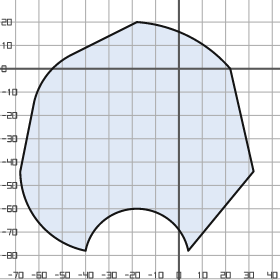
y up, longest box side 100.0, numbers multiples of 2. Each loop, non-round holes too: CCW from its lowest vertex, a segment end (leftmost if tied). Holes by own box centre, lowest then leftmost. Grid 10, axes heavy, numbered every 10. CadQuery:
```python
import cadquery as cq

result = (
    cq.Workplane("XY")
    .moveTo(-40.0, -78.0)
    .threePointArc((-18.0, -60.0), (4.0, -78.0))
    .lineTo(32.0, -44.0)
    .lineTo(22.0, 0.0)
    .threePointArc((4.0, 14.0), (-18.0, 20.0))
    .lineTo(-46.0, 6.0)
    .threePointArc((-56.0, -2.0), (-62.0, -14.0))
    .lineTo(-68.0, -44.0)
    .threePointArc((-60.0, -66.0), (-40.0, -78.0))
    .close()
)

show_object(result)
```